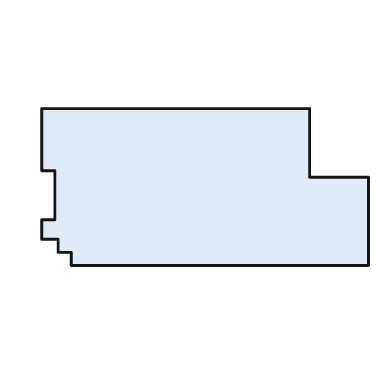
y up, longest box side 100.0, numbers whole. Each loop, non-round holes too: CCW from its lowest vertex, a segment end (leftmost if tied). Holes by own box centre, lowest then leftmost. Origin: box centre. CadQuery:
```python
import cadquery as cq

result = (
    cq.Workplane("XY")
    .moveTo(-41.0, -24.0)
    .lineTo(50.0, -24.0)
    .lineTo(50.0, 3.0)
    .lineTo(32.0, 3.0)
    .lineTo(32.0, 24.0)
    .lineTo(-50.0, 24.0)
    .lineTo(-50.0, 5.0)
    .lineTo(-46.0, 5.0)
    .lineTo(-46.0, -10.0)
    .lineTo(-50.0, -10.0)
    .lineTo(-50.0, -16.0)
    .lineTo(-45.0, -16.0)
    .lineTo(-45.0, -20.0)
    .lineTo(-41.0, -20.0)
    .close()
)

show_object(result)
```